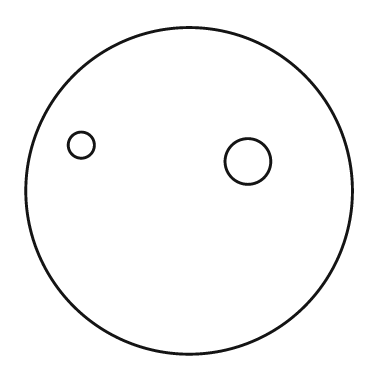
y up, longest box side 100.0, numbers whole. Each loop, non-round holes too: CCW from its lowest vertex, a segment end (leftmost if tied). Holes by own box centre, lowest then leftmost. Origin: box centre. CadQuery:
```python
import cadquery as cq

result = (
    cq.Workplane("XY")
    .moveTo(0.0, 0.0)
    .circle(50.0)
    .moveTo(18.0, 9.0)
    .circle(7.0)
    .moveTo(-33.0, 14.0)
    .circle(4.0)
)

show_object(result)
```